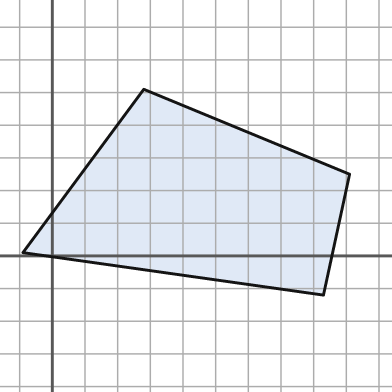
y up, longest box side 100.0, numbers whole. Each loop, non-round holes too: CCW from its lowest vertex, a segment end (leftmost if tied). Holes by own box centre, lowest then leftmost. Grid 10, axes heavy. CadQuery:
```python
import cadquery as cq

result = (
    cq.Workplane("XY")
    .moveTo(83.0, -12.0)
    .lineTo(91.0, 25.0)
    .lineTo(28.0, 51.0)
    .lineTo(-9.0, 1.0)
    .close()
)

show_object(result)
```